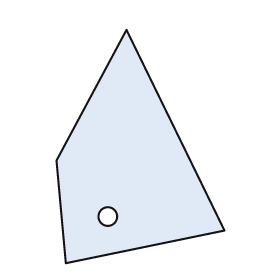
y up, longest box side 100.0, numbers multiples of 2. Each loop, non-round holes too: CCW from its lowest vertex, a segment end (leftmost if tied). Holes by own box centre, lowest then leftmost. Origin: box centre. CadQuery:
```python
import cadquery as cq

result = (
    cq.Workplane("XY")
    .moveTo(-32.0, -50.0)
    .lineTo(36.0, -36.0)
    .lineTo(-6.0, 50.0)
    .lineTo(-36.0, -6.0)
    .close()
    .moveTo(-14.0, -30.0)
    .circle(4.0)
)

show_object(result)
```